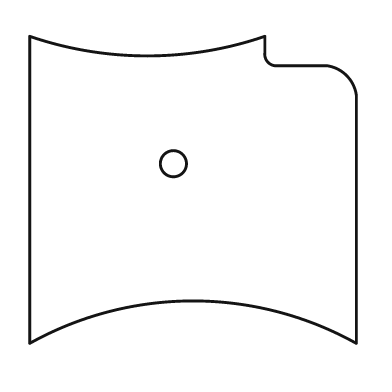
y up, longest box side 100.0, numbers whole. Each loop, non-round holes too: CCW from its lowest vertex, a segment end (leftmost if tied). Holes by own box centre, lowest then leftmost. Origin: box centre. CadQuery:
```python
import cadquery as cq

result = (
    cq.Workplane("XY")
    .moveTo(-50.0, -47.0)
    .threePointArc((0.0, -34.0), (50.0, -47.0))
    .lineTo(50.0, 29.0)
    .threePointArc((47.0, 35.0), (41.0, 38.0))
    .lineTo(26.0, 38.0)
    .threePointArc((23.0, 39.0), (22.0, 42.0))
    .lineTo(22.0, 47.0)
    .threePointArc((-14.0, 41.0), (-50.0, 47.0))
    .close()
    .moveTo(-6.0, 8.0)
    .circle(4.0)
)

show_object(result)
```